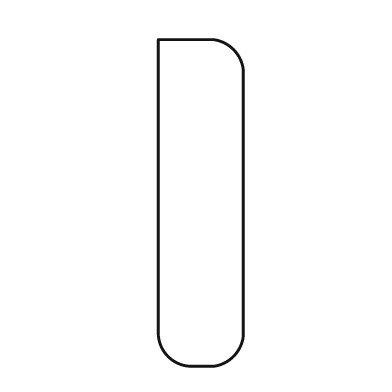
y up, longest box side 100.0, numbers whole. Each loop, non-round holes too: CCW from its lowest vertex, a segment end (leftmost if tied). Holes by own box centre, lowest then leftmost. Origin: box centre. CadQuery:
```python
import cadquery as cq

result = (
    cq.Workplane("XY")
    .moveTo(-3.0, -50.0)
    .lineTo(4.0, -50.0)
    .threePointArc((10.0, -47.0), (13.0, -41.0))
    .lineTo(13.0, 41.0)
    .threePointArc((10.0, 47.0), (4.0, 50.0))
    .lineTo(-13.0, 50.0)
    .lineTo(-13.0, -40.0)
    .threePointArc((-10.0, -47.0), (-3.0, -50.0))
    .close()
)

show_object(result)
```